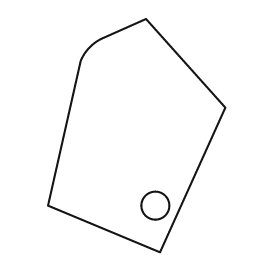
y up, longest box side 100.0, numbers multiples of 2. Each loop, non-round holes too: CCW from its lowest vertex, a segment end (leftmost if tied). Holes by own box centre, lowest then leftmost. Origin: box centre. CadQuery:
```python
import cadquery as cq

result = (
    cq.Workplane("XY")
    .moveTo(10.0, -50.0)
    .lineTo(38.0, 12.0)
    .lineTo(4.0, 50.0)
    .lineTo(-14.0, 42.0)
    .threePointArc((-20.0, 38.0), (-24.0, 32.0))
    .lineTo(-38.0, -30.0)
    .close()
    .moveTo(8.0, -30.0)
    .circle(6.0)
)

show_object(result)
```